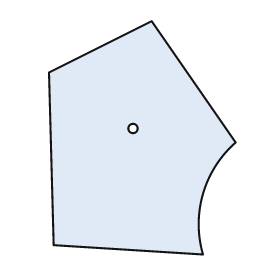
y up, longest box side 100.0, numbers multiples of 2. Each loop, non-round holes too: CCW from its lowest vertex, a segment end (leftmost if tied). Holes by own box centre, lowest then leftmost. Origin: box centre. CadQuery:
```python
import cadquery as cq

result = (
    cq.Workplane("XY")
    .moveTo(26.0, -50.0)
    .threePointArc((26.0, -24.0), (40.0, -2.0))
    .lineTo(4.0, 50.0)
    .lineTo(-40.0, 28.0)
    .lineTo(-38.0, -46.0)
    .close()
    .moveTo(-4.0, 4.0)
    .circle(2.0)
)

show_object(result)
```